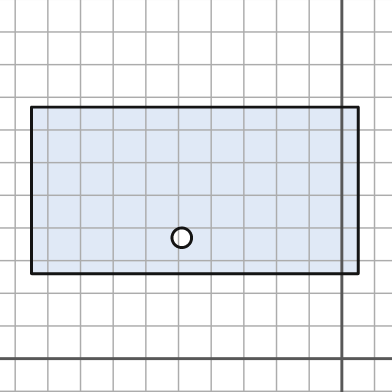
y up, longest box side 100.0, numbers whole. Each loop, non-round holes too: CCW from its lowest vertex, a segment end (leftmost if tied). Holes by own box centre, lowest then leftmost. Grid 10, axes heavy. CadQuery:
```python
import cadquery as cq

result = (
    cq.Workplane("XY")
    .moveTo(-95.0, 26.0)
    .lineTo(5.0, 26.0)
    .lineTo(5.0, 77.0)
    .lineTo(-95.0, 77.0)
    .close()
    .moveTo(-49.0, 37.0)
    .circle(3.0)
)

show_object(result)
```